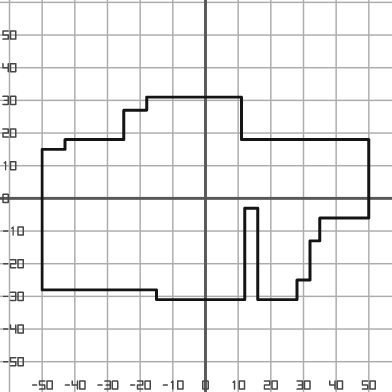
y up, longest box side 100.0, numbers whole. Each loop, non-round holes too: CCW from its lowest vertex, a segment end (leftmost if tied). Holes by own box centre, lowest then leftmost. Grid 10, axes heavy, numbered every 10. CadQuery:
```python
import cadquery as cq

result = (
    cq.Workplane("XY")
    .moveTo(-15.0, -31.0)
    .lineTo(12.0, -31.0)
    .lineTo(12.0, -3.0)
    .lineTo(16.0, -3.0)
    .lineTo(16.0, -31.0)
    .lineTo(28.0, -31.0)
    .lineTo(28.0, -25.0)
    .lineTo(32.0, -25.0)
    .lineTo(32.0, -13.0)
    .lineTo(35.0, -13.0)
    .lineTo(35.0, -6.0)
    .lineTo(50.0, -6.0)
    .lineTo(50.0, 18.0)
    .lineTo(11.0, 18.0)
    .lineTo(11.0, 31.0)
    .lineTo(-18.0, 31.0)
    .lineTo(-18.0, 27.0)
    .lineTo(-25.0, 27.0)
    .lineTo(-25.0, 18.0)
    .lineTo(-43.0, 18.0)
    .lineTo(-43.0, 15.0)
    .lineTo(-50.0, 15.0)
    .lineTo(-50.0, -28.0)
    .lineTo(-15.0, -28.0)
    .close()
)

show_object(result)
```